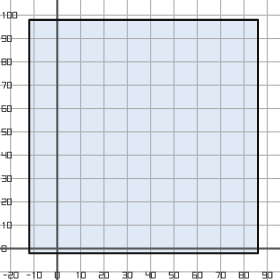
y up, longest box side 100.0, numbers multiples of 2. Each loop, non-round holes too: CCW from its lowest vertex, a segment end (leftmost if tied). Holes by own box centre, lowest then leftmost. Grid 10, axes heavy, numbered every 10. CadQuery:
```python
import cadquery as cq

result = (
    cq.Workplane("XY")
    .moveTo(-12.0, -2.0)
    .lineTo(86.0, -2.0)
    .lineTo(86.0, 98.0)
    .lineTo(-12.0, 98.0)
    .close()
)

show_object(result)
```